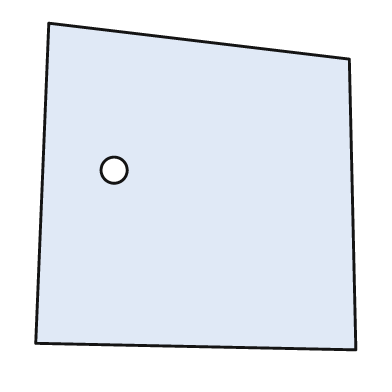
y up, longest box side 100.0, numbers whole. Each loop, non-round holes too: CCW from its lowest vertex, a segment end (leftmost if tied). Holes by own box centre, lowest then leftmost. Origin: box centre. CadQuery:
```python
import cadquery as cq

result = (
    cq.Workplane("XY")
    .moveTo(49.0, -50.0)
    .lineTo(47.0, 39.0)
    .lineTo(-45.0, 50.0)
    .lineTo(-49.0, -48.0)
    .close()
    .moveTo(-25.0, 5.0)
    .circle(4.0)
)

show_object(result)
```